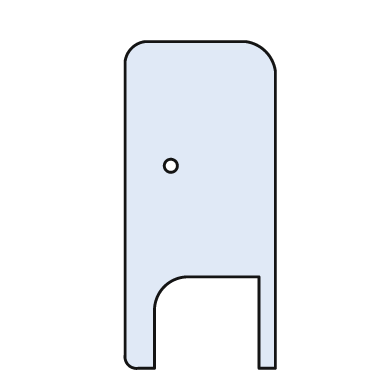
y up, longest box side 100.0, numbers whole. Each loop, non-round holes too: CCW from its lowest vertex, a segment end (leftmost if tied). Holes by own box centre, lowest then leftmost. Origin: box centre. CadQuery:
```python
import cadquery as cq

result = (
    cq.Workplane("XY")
    .moveTo(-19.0, -50.0)
    .lineTo(-14.0, -50.0)
    .lineTo(-14.0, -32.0)
    .threePointArc((-11.0, -25.0), (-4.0, -22.0))
    .lineTo(18.0, -22.0)
    .lineTo(18.0, -50.0)
    .lineTo(23.0, -50.0)
    .lineTo(23.0, 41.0)
    .threePointArc((20.0, 47.0), (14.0, 50.0))
    .lineTo(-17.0, 50.0)
    .threePointArc((-21.0, 48.0), (-23.0, 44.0))
    .lineTo(-23.0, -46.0)
    .threePointArc((-22.0, -49.0), (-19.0, -50.0))
    .close()
    .moveTo(-9.0, 12.0)
    .circle(2.0)
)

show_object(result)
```